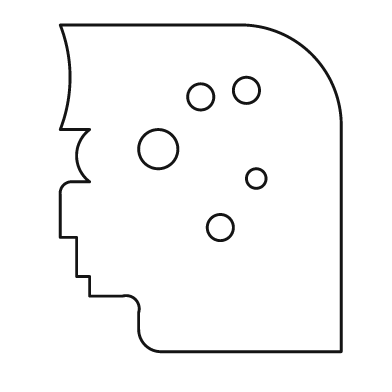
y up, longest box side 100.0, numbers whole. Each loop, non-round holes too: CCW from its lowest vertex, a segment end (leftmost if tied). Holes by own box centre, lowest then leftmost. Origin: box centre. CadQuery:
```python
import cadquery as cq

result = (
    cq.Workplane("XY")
    .moveTo(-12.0, -50.0)
    .lineTo(43.0, -50.0)
    .lineTo(43.0, 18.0)
    .threePointArc((34.0, 41.0), (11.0, 50.0))
    .lineTo(-43.0, 50.0)
    .threePointArc((-40.0, 34.0), (-43.0, 18.0))
    .lineTo(-34.0, 18.0)
    .threePointArc((-38.0, 10.0), (-34.0, 2.0))
    .lineTo(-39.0, 2.0)
    .threePointArc((-42.0, 1.0), (-43.0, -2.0))
    .lineTo(-43.0, -15.0)
    .lineTo(-38.0, -15.0)
    .lineTo(-38.0, -27.0)
    .lineTo(-34.0, -27.0)
    .lineTo(-34.0, -33.0)
    .lineTo(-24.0, -33.0)
    .threePointArc((-20.0, -34.0), (-19.0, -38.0))
    .lineTo(-19.0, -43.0)
    .threePointArc((-17.0, -48.0), (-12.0, -50.0))
    .close()
    .moveTo(6.0, -12.0)
    .circle(4.0)
    .moveTo(17.0, 3.0)
    .circle(3.0)
    .moveTo(-13.0, 12.0)
    .circle(6.0)
    .moveTo(0.0, 28.0)
    .circle(4.0)
    .moveTo(14.0, 30.0)
    .circle(4.0)
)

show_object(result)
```